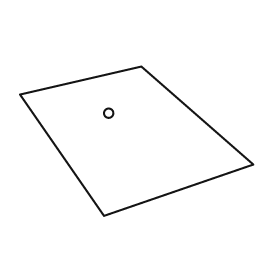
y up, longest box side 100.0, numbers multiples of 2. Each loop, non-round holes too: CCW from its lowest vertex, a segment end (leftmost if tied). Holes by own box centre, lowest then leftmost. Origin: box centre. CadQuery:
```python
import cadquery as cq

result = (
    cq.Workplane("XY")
    .moveTo(-14.0, -32.0)
    .lineTo(50.0, -10.0)
    .lineTo(2.0, 32.0)
    .lineTo(-50.0, 20.0)
    .close()
    .moveTo(-12.0, 12.0)
    .circle(2.0)
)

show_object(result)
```